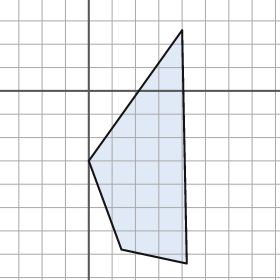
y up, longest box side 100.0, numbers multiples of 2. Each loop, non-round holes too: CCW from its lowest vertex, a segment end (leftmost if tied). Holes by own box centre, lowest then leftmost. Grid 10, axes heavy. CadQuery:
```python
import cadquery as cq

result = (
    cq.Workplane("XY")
    .moveTo(42.0, -74.0)
    .lineTo(40.0, 26.0)
    .lineTo(0.0, -30.0)
    .lineTo(14.0, -68.0)
    .close()
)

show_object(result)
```